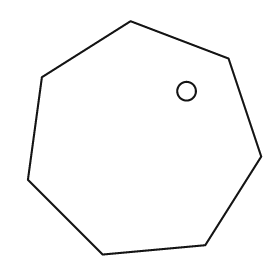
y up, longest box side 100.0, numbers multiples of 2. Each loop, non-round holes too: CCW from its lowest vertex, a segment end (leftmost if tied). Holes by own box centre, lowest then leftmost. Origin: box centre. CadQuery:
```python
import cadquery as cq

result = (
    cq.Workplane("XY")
    .moveTo(-18.0, -50.0)
    .lineTo(26.0, -46.0)
    .lineTo(50.0, -8.0)
    .lineTo(36.0, 34.0)
    .lineTo(-6.0, 50.0)
    .lineTo(-44.0, 26.0)
    .lineTo(-50.0, -18.0)
    .close()
    .moveTo(18.0, 20.0)
    .circle(4.0)
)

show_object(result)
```